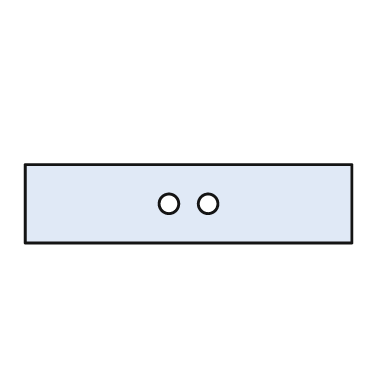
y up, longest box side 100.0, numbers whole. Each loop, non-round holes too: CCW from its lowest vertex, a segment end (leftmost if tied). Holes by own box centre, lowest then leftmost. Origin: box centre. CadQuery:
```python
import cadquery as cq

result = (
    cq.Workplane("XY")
    .moveTo(-50.0, -12.0)
    .lineTo(50.0, -12.0)
    .lineTo(50.0, 12.0)
    .lineTo(-50.0, 12.0)
    .close()
    .moveTo(-6.0, 0.0)
    .circle(3.0)
    .moveTo(6.0, 0.0)
    .circle(3.0)
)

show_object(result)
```